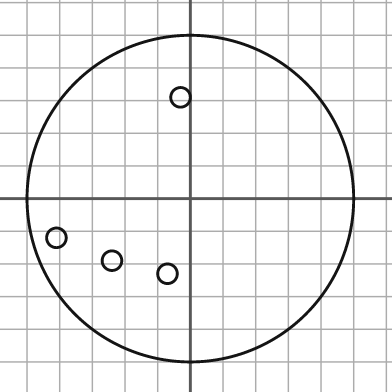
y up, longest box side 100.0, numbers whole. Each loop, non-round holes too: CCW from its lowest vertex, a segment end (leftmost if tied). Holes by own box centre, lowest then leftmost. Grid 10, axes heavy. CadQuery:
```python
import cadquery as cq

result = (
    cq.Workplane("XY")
    .moveTo(0.0, 0.0)
    .circle(50.0)
    .moveTo(-7.0, -23.0)
    .circle(3.0)
    .moveTo(-24.0, -19.0)
    .circle(3.0)
    .moveTo(-41.0, -12.0)
    .circle(3.0)
    .moveTo(-3.0, 31.0)
    .circle(3.0)
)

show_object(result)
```